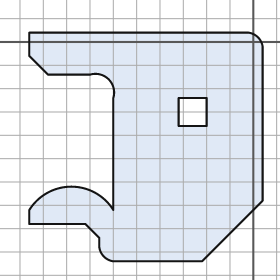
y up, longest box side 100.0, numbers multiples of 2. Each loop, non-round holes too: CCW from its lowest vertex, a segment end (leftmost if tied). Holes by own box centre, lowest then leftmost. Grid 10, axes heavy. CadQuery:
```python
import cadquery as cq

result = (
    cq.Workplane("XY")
    .moveTo(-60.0, -94.0)
    .lineTo(-22.0, -94.0)
    .lineTo(4.0, -68.0)
    .lineTo(4.0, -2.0)
    .threePointArc((2.0, 2.0), (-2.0, 4.0))
    .lineTo(-96.0, 4.0)
    .lineTo(-96.0, -6.0)
    .lineTo(-88.0, -14.0)
    .lineTo(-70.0, -14.0)
    .threePointArc((-62.0, -16.0), (-60.0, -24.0))
    .lineTo(-60.0, -72.0)
    .threePointArc((-78.0, -62.0), (-96.0, -72.0))
    .lineTo(-96.0, -78.0)
    .lineTo(-72.0, -78.0)
    .lineTo(-66.0, -84.0)
    .lineTo(-66.0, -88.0)
    .threePointArc((-64.0, -92.0), (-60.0, -94.0))
    .close()
    .moveTo(-32.0, -36.0)
    .lineTo(-20.0, -36.0)
    .lineTo(-20.0, -24.0)
    .lineTo(-32.0, -24.0)
    .close()
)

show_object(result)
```